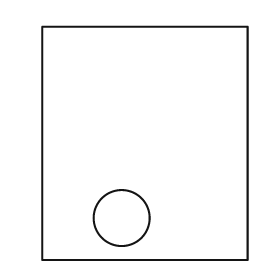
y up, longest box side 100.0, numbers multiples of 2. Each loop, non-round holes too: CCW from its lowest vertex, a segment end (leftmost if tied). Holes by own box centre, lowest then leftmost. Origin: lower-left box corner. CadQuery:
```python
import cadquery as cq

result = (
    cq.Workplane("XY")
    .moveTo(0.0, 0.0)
    .lineTo(88.0, 0.0)
    .lineTo(88.0, 100.0)
    .lineTo(0.0, 100.0)
    .close()
    .moveTo(34.0, 18.0)
    .circle(12.0)
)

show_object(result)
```